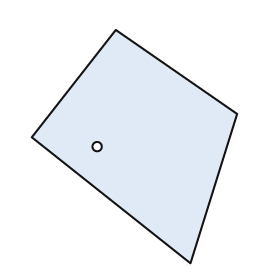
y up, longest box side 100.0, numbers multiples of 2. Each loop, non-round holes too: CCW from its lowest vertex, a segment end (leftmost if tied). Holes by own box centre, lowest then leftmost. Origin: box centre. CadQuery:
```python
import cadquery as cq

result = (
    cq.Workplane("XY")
    .moveTo(24.0, -50.0)
    .lineTo(44.0, 14.0)
    .lineTo(-8.0, 50.0)
    .lineTo(-44.0, 4.0)
    .close()
    .moveTo(-16.0, 0.0)
    .circle(2.0)
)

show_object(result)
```